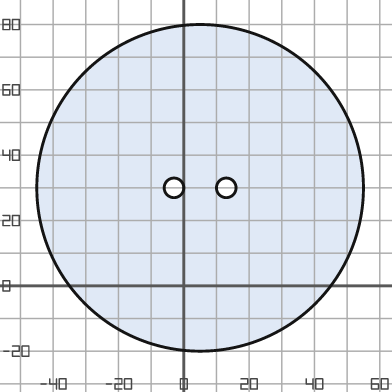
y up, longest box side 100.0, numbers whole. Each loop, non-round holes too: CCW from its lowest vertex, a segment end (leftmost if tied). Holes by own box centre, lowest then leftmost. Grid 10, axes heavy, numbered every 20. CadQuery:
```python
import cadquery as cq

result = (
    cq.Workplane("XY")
    .moveTo(5.0, 30.0)
    .circle(50.0)
    .moveTo(-3.0, 30.0)
    .circle(3.0)
    .moveTo(13.0, 30.0)
    .circle(3.0)
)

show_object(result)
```